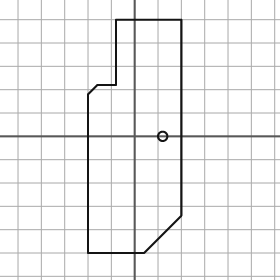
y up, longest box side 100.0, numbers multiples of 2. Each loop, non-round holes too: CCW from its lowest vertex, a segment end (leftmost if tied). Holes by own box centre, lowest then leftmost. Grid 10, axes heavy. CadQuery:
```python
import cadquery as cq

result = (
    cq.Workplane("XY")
    .moveTo(-20.0, -50.0)
    .lineTo(4.0, -50.0)
    .lineTo(20.0, -34.0)
    .lineTo(20.0, 50.0)
    .lineTo(-8.0, 50.0)
    .lineTo(-8.0, 22.0)
    .lineTo(-16.0, 22.0)
    .lineTo(-20.0, 18.0)
    .close()
    .moveTo(12.0, 0.0)
    .circle(2.0)
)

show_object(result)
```